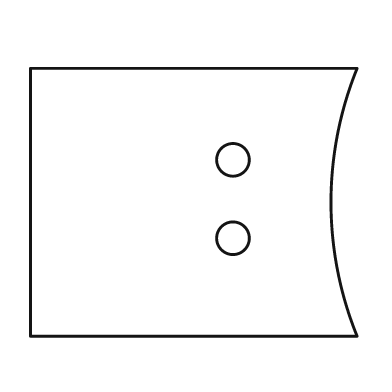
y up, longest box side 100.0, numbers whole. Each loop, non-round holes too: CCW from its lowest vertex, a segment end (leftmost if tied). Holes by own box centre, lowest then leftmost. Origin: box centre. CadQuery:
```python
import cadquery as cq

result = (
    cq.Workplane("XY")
    .moveTo(-50.0, -41.0)
    .lineTo(50.0, -41.0)
    .threePointArc((42.0, 0.0), (50.0, 41.0))
    .lineTo(-50.0, 41.0)
    .close()
    .moveTo(12.0, -11.0)
    .circle(5.0)
    .moveTo(12.0, 13.0)
    .circle(5.0)
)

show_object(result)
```